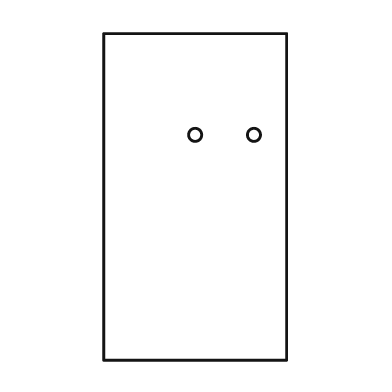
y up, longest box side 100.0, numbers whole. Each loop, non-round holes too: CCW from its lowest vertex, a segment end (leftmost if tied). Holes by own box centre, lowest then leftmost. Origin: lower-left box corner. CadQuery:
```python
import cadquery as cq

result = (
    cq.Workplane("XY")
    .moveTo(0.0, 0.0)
    .lineTo(56.0, 0.0)
    .lineTo(56.0, 100.0)
    .lineTo(0.0, 100.0)
    .close()
    .moveTo(28.0, 69.0)
    .circle(2.0)
    .moveTo(46.0, 69.0)
    .circle(2.0)
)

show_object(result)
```